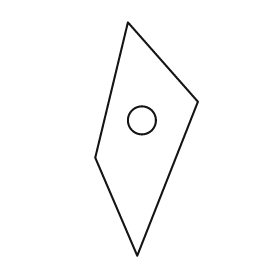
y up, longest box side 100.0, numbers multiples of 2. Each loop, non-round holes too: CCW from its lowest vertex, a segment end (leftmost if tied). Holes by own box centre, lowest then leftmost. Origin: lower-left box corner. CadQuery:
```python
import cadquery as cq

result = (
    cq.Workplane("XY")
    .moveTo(18.0, 0.0)
    .lineTo(44.0, 66.0)
    .lineTo(14.0, 100.0)
    .lineTo(0.0, 42.0)
    .close()
    .moveTo(20.0, 58.0)
    .circle(6.0)
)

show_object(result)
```